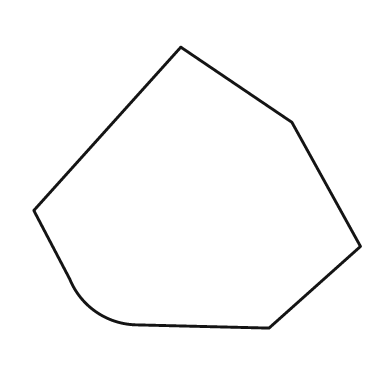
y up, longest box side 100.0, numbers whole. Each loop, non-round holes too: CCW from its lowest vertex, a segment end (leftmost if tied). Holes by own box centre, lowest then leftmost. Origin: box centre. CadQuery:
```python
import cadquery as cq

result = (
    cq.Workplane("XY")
    .moveTo(22.0, -43.0)
    .lineTo(50.0, -18.0)
    .lineTo(29.0, 20.0)
    .lineTo(-5.0, 43.0)
    .lineTo(-50.0, -7.0)
    .lineTo(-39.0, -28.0)
    .threePointArc((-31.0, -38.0), (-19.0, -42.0))
    .close()
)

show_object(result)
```